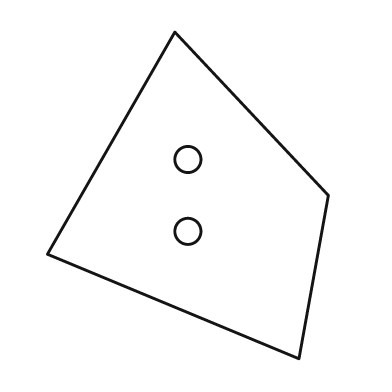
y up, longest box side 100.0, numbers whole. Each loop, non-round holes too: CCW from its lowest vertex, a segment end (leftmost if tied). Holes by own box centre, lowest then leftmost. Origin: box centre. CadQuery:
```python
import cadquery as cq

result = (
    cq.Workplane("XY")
    .moveTo(34.0, -50.0)
    .lineTo(43.0, 0.0)
    .lineTo(-4.0, 50.0)
    .lineTo(-43.0, -18.0)
    .close()
    .moveTo(0.0, -11.0)
    .circle(4.0)
    .moveTo(0.0, 11.0)
    .circle(4.0)
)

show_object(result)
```